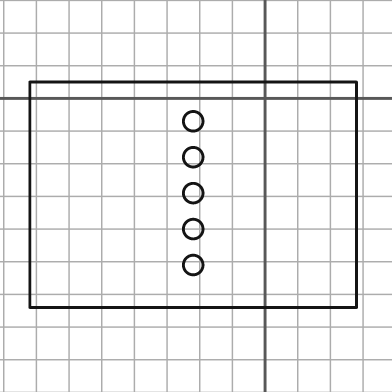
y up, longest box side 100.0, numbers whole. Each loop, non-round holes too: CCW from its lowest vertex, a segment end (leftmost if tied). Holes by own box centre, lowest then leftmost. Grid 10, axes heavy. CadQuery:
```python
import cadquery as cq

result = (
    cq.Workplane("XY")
    .moveTo(-72.0, -64.0)
    .lineTo(28.0, -64.0)
    .lineTo(28.0, 5.0)
    .lineTo(-72.0, 5.0)
    .close()
    .moveTo(-22.0, -51.0)
    .circle(3.0)
    .moveTo(-22.0, -40.0)
    .circle(3.0)
    .moveTo(-22.0, -29.0)
    .circle(3.0)
    .moveTo(-22.0, -18.0)
    .circle(3.0)
    .moveTo(-22.0, -7.0)
    .circle(3.0)
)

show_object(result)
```